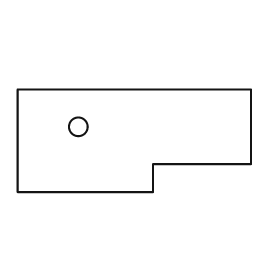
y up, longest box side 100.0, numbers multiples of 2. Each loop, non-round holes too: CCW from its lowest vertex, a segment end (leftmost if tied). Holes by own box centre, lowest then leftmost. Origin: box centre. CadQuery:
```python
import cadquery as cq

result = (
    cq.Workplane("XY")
    .moveTo(-50.0, -22.0)
    .lineTo(8.0, -22.0)
    .lineTo(8.0, -10.0)
    .lineTo(50.0, -10.0)
    .lineTo(50.0, 22.0)
    .lineTo(-50.0, 22.0)
    .close()
    .moveTo(-24.0, 6.0)
    .circle(4.0)
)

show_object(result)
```